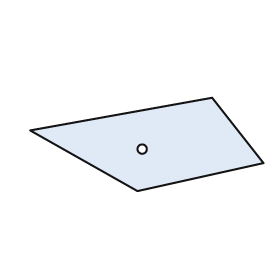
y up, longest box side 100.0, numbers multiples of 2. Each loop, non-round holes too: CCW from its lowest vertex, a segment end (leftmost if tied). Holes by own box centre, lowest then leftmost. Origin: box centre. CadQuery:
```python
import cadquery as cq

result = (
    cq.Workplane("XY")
    .moveTo(-4.0, -20.0)
    .lineTo(50.0, -8.0)
    .lineTo(28.0, 20.0)
    .lineTo(-50.0, 6.0)
    .close()
    .moveTo(-2.0, -2.0)
    .circle(2.0)
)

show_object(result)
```